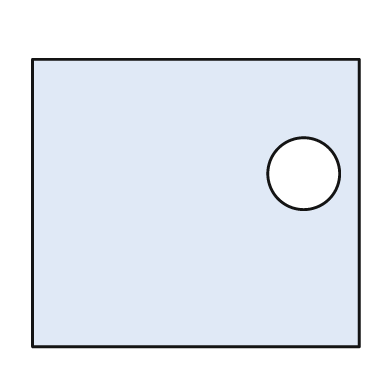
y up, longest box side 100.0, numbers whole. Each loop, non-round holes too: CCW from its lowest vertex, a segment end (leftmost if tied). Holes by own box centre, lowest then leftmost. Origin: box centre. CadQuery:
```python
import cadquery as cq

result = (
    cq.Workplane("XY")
    .moveTo(-50.0, -44.0)
    .lineTo(50.0, -44.0)
    .lineTo(50.0, 44.0)
    .lineTo(-50.0, 44.0)
    .close()
    .moveTo(33.0, 9.0)
    .circle(11.0)
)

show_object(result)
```